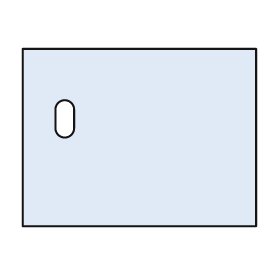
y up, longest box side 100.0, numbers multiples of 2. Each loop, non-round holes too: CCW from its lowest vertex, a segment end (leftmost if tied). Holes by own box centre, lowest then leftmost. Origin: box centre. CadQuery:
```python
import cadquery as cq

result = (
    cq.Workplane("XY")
    .moveTo(-50.0, -38.0)
    .lineTo(50.0, -38.0)
    .lineTo(50.0, 38.0)
    .lineTo(-50.0, 38.0)
    .close()
    .moveTo(-36.0, 4.0)
    .threePointArc((-32.0, 0.0), (-28.0, 4.0))
    .lineTo(-28.0, 12.0)
    .threePointArc((-32.0, 16.0), (-36.0, 12.0))
    .close()
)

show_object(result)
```